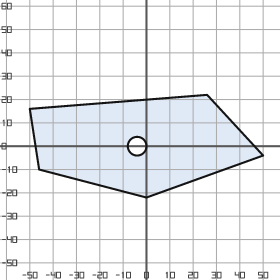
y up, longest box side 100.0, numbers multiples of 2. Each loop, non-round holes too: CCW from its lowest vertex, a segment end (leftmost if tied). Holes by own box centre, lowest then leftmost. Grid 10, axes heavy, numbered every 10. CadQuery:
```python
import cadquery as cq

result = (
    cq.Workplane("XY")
    .moveTo(0.0, -22.0)
    .lineTo(50.0, -4.0)
    .lineTo(26.0, 22.0)
    .lineTo(-50.0, 16.0)
    .lineTo(-46.0, -10.0)
    .close()
    .moveTo(-4.0, 0.0)
    .circle(4.0)
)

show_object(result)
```